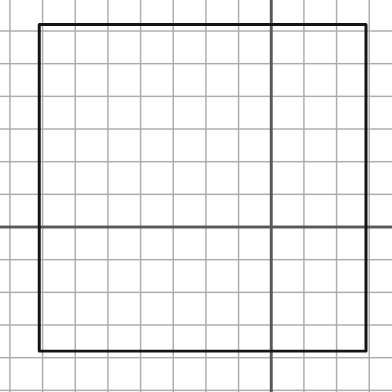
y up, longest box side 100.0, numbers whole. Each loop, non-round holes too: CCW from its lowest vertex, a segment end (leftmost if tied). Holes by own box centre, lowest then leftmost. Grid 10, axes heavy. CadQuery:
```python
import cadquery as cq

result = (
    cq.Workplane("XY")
    .moveTo(-71.0, -38.0)
    .lineTo(29.0, -38.0)
    .lineTo(29.0, 62.0)
    .lineTo(-71.0, 62.0)
    .close()
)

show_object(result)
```